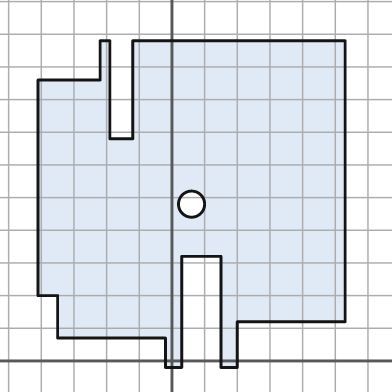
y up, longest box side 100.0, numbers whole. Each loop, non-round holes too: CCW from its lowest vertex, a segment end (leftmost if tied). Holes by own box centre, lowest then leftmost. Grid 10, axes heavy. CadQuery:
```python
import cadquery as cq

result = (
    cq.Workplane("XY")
    .moveTo(-2.0, -2.0)
    .lineTo(3.0, -2.0)
    .lineTo(3.0, 32.0)
    .lineTo(15.0, 32.0)
    .lineTo(15.0, -2.0)
    .lineTo(20.0, -2.0)
    .lineTo(20.0, 12.0)
    .lineTo(53.0, 12.0)
    .lineTo(53.0, 98.0)
    .lineTo(-12.0, 98.0)
    .lineTo(-12.0, 68.0)
    .lineTo(-19.0, 68.0)
    .lineTo(-19.0, 98.0)
    .lineTo(-22.0, 98.0)
    .lineTo(-22.0, 86.0)
    .lineTo(-41.0, 86.0)
    .lineTo(-41.0, 20.0)
    .lineTo(-35.0, 20.0)
    .lineTo(-35.0, 7.0)
    .lineTo(-2.0, 7.0)
    .close()
    .moveTo(6.0, 48.0)
    .circle(4.0)
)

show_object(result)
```